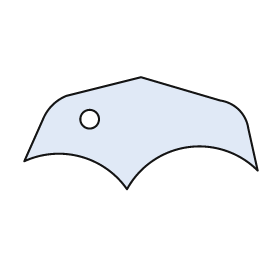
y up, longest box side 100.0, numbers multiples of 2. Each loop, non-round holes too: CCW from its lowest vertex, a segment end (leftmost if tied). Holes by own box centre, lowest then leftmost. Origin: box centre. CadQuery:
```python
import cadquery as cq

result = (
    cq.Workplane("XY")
    .moveTo(-6.0, -24.0)
    .threePointArc((20.0, -6.0), (50.0, -16.0))
    .lineTo(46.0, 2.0)
    .threePointArc((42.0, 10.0), (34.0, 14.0))
    .lineTo(0.0, 24.0)
    .lineTo(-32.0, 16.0)
    .threePointArc((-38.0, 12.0), (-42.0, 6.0))
    .lineTo(-50.0, -12.0)
    .threePointArc((-26.0, -10.0), (-6.0, -24.0))
    .close()
    .moveTo(-22.0, 6.0)
    .circle(4.0)
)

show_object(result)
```